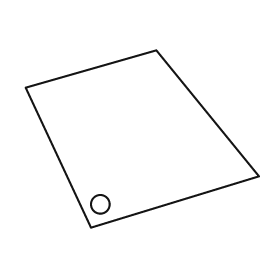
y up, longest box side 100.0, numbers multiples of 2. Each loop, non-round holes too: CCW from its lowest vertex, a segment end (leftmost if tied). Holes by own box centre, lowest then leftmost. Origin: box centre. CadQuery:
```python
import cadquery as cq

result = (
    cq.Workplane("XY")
    .moveTo(-22.0, -38.0)
    .lineTo(50.0, -16.0)
    .lineTo(6.0, 38.0)
    .lineTo(-50.0, 22.0)
    .close()
    .moveTo(-18.0, -28.0)
    .circle(4.0)
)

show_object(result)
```